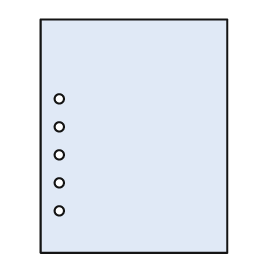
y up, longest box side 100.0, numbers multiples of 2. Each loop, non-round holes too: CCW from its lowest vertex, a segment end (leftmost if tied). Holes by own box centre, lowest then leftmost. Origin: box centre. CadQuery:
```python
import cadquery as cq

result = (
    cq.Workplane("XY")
    .moveTo(-40.0, -50.0)
    .lineTo(40.0, -50.0)
    .lineTo(40.0, 50.0)
    .lineTo(-40.0, 50.0)
    .close()
    .moveTo(-32.0, -32.0)
    .circle(2.0)
    .moveTo(-32.0, -20.0)
    .circle(2.0)
    .moveTo(-32.0, -8.0)
    .circle(2.0)
    .moveTo(-32.0, 4.0)
    .circle(2.0)
    .moveTo(-32.0, 16.0)
    .circle(2.0)
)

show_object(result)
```